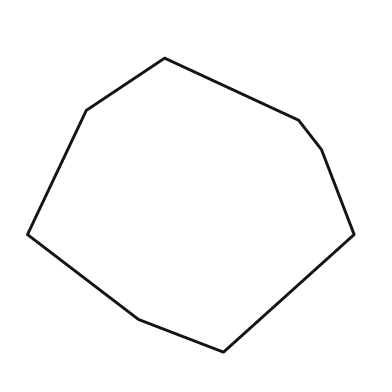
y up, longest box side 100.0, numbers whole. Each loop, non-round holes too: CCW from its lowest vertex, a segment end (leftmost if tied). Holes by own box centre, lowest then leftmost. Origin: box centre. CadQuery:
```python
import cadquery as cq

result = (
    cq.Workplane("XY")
    .moveTo(10.0, -45.0)
    .lineTo(50.0, -9.0)
    .lineTo(40.0, 17.0)
    .lineTo(33.0, 26.0)
    .lineTo(-8.0, 45.0)
    .lineTo(-32.0, 29.0)
    .lineTo(-50.0, -9.0)
    .lineTo(-16.0, -35.0)
    .close()
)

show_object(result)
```